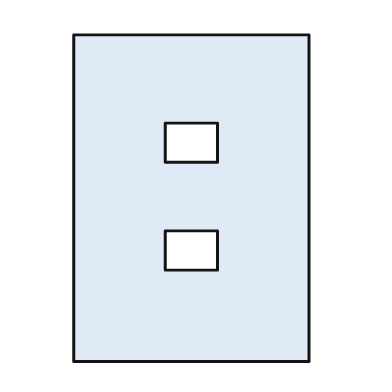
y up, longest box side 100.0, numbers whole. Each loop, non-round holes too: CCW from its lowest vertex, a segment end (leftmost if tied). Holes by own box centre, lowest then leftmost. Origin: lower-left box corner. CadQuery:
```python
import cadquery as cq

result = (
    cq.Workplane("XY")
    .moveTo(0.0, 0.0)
    .lineTo(72.0, 0.0)
    .lineTo(72.0, 100.0)
    .lineTo(0.0, 100.0)
    .close()
    .moveTo(28.0, 28.0)
    .lineTo(44.0, 28.0)
    .lineTo(44.0, 40.0)
    .lineTo(28.0, 40.0)
    .close()
    .moveTo(28.0, 61.0)
    .lineTo(44.0, 61.0)
    .lineTo(44.0, 73.0)
    .lineTo(28.0, 73.0)
    .close()
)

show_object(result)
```